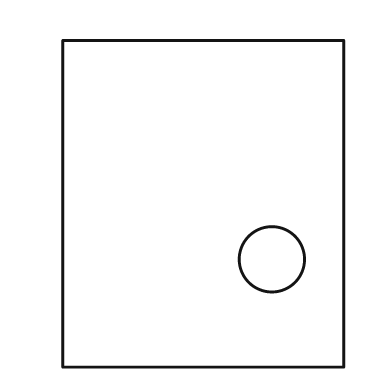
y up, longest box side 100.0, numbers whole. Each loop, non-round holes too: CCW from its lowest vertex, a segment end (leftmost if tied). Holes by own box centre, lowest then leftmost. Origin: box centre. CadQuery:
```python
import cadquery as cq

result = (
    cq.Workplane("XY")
    .moveTo(-43.0, -50.0)
    .lineTo(43.0, -50.0)
    .lineTo(43.0, 50.0)
    .lineTo(-43.0, 50.0)
    .close()
    .moveTo(21.0, -17.0)
    .circle(10.0)
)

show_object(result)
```